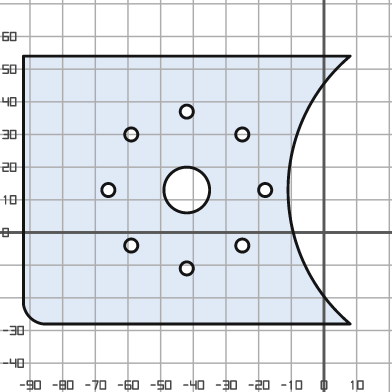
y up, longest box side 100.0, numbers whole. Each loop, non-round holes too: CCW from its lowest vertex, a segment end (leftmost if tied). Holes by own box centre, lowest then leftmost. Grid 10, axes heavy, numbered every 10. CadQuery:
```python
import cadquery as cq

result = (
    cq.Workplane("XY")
    .moveTo(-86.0, -28.0)
    .lineTo(8.0, -28.0)
    .threePointArc((-11.0, 13.0), (8.0, 54.0))
    .lineTo(-92.0, 54.0)
    .lineTo(-92.0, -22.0)
    .threePointArc((-90.0, -26.0), (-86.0, -28.0))
    .close()
    .moveTo(-42.0, -11.0)
    .circle(2.0)
    .moveTo(-59.0, -4.0)
    .circle(2.0)
    .moveTo(-25.0, -4.0)
    .circle(2.0)
    .moveTo(-66.0, 13.0)
    .circle(2.0)
    .moveTo(-42.0, 13.0)
    .circle(7.0)
    .moveTo(-18.0, 13.0)
    .circle(2.0)
    .moveTo(-59.0, 30.0)
    .circle(2.0)
    .moveTo(-25.0, 30.0)
    .circle(2.0)
    .moveTo(-42.0, 37.0)
    .circle(2.0)
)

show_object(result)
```